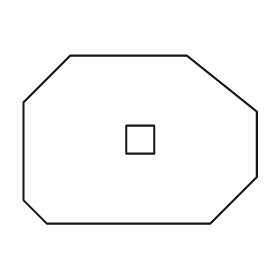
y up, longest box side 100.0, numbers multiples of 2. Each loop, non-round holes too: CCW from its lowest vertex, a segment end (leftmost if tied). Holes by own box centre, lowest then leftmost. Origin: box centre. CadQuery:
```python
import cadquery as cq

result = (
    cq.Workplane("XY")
    .moveTo(-40.0, -36.0)
    .lineTo(30.0, -36.0)
    .lineTo(50.0, -16.0)
    .lineTo(50.0, 12.0)
    .lineTo(20.0, 36.0)
    .lineTo(-30.0, 36.0)
    .lineTo(-50.0, 16.0)
    .lineTo(-50.0, -26.0)
    .close()
    .moveTo(-6.0, -6.0)
    .lineTo(6.0, -6.0)
    .lineTo(6.0, 6.0)
    .lineTo(-6.0, 6.0)
    .close()
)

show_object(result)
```